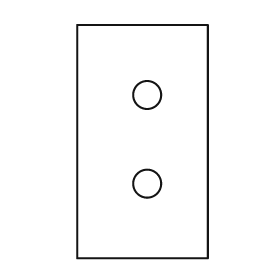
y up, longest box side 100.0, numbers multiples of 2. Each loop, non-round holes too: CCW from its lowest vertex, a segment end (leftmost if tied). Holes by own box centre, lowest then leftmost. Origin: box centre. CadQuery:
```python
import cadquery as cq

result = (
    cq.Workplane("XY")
    .moveTo(-28.0, -50.0)
    .lineTo(28.0, -50.0)
    .lineTo(28.0, 50.0)
    .lineTo(-28.0, 50.0)
    .close()
    .moveTo(2.0, -18.0)
    .circle(6.0)
    .moveTo(2.0, 20.0)
    .circle(6.0)
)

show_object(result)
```